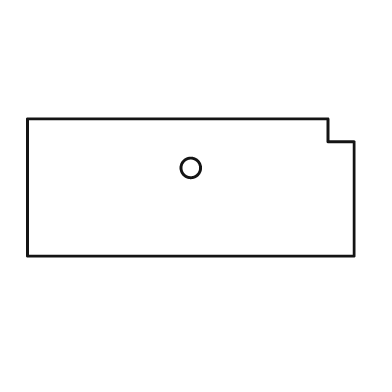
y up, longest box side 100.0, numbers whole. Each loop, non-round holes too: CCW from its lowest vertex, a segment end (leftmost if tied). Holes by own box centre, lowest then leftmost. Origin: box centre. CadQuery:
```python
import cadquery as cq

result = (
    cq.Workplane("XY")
    .moveTo(-50.0, -21.0)
    .lineTo(50.0, -21.0)
    .lineTo(50.0, 14.0)
    .lineTo(42.0, 14.0)
    .lineTo(42.0, 21.0)
    .lineTo(-50.0, 21.0)
    .close()
    .moveTo(0.0, 6.0)
    .circle(3.0)
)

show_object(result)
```